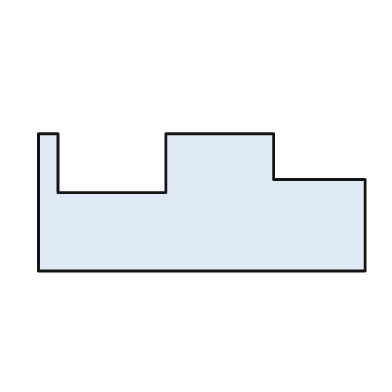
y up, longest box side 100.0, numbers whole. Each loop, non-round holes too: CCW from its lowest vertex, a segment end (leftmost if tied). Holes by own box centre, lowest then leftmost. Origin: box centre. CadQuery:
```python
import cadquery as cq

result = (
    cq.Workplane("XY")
    .moveTo(-50.0, -21.0)
    .lineTo(50.0, -21.0)
    .lineTo(50.0, 7.0)
    .lineTo(22.0, 7.0)
    .lineTo(22.0, 21.0)
    .lineTo(-11.0, 21.0)
    .lineTo(-11.0, 3.0)
    .lineTo(-44.0, 3.0)
    .lineTo(-44.0, 21.0)
    .lineTo(-50.0, 21.0)
    .close()
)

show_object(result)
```